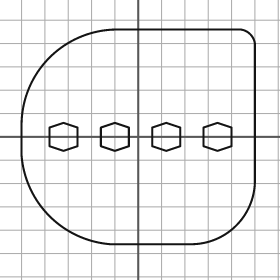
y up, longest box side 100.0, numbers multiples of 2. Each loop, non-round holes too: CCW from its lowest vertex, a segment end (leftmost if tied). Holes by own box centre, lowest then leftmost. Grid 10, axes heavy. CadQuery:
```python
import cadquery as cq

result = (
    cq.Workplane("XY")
    .moveTo(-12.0, -46.0)
    .lineTo(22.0, -46.0)
    .threePointArc((42.0, -38.0), (50.0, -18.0))
    .lineTo(50.0, 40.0)
    .threePointArc((48.0, 44.0), (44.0, 46.0))
    .lineTo(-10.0, 46.0)
    .threePointArc((-38.0, 34.0), (-50.0, 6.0))
    .lineTo(-50.0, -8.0)
    .threePointArc((-38.0, -34.0), (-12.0, -46.0))
    .close()
    .moveTo(-32.0, -6.0)
    .lineTo(-26.0, -4.0)
    .lineTo(-26.0, 4.0)
    .lineTo(-32.0, 6.0)
    .lineTo(-38.0, 4.0)
    .lineTo(-38.0, -4.0)
    .close()
    .moveTo(-10.0, -6.0)
    .lineTo(-4.0, -4.0)
    .lineTo(-4.0, 4.0)
    .lineTo(-10.0, 6.0)
    .lineTo(-16.0, 4.0)
    .lineTo(-16.0, -4.0)
    .close()
    .moveTo(12.0, -6.0)
    .lineTo(18.0, -4.0)
    .lineTo(18.0, 4.0)
    .lineTo(12.0, 6.0)
    .lineTo(6.0, 4.0)
    .lineTo(6.0, -4.0)
    .close()
    .moveTo(34.0, -6.0)
    .lineTo(40.0, -4.0)
    .lineTo(40.0, 4.0)
    .lineTo(34.0, 6.0)
    .lineTo(28.0, 4.0)
    .lineTo(28.0, -4.0)
    .close()
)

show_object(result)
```